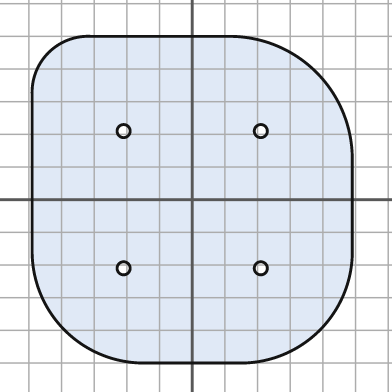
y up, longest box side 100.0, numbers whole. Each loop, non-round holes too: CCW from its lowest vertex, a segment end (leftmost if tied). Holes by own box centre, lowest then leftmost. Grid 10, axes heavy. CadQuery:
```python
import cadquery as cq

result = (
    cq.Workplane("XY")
    .moveTo(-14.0, -50.0)
    .lineTo(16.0, -50.0)
    .threePointArc((39.0, -40.0), (49.0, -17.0))
    .lineTo(49.0, 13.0)
    .threePointArc((38.0, 39.0), (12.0, 50.0))
    .lineTo(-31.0, 50.0)
    .threePointArc((-44.0, 45.0), (-49.0, 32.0))
    .lineTo(-49.0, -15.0)
    .threePointArc((-39.0, -40.0), (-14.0, -50.0))
    .close()
    .moveTo(-21.0, -21.0)
    .circle(2.0)
    .moveTo(21.0, -21.0)
    .circle(2.0)
    .moveTo(-21.0, 21.0)
    .circle(2.0)
    .moveTo(21.0, 21.0)
    .circle(2.0)
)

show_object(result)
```